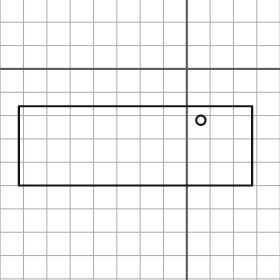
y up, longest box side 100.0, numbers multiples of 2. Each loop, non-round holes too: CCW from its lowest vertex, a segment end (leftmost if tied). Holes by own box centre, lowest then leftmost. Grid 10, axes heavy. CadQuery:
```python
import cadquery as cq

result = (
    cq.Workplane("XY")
    .moveTo(-72.0, -50.0)
    .lineTo(28.0, -50.0)
    .lineTo(28.0, -16.0)
    .lineTo(-72.0, -16.0)
    .close()
    .moveTo(6.0, -22.0)
    .circle(2.0)
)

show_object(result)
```